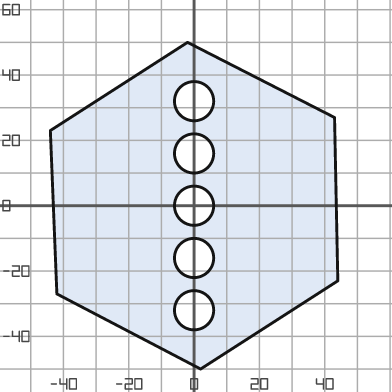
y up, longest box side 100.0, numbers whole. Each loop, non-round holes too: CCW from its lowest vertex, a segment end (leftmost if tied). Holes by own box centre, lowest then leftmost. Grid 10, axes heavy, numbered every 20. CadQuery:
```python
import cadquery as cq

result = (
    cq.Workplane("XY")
    .moveTo(2.0, -50.0)
    .lineTo(44.0, -23.0)
    .lineTo(43.0, 27.0)
    .lineTo(-2.0, 50.0)
    .lineTo(-44.0, 23.0)
    .lineTo(-42.0, -27.0)
    .close()
    .moveTo(0.0, -32.0)
    .circle(6.0)
    .moveTo(0.0, -16.0)
    .circle(6.0)
    .moveTo(0.0, 0.0)
    .circle(6.0)
    .moveTo(0.0, 16.0)
    .circle(6.0)
    .moveTo(0.0, 32.0)
    .circle(6.0)
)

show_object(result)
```